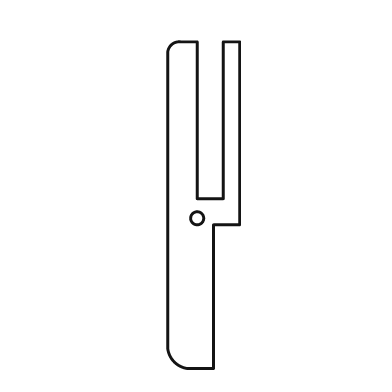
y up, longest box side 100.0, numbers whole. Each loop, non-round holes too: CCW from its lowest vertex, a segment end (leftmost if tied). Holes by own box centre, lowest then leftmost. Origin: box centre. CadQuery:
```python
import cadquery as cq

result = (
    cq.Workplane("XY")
    .moveTo(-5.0, -50.0)
    .lineTo(3.0, -50.0)
    .lineTo(3.0, -6.0)
    .lineTo(11.0, -6.0)
    .lineTo(11.0, 50.0)
    .lineTo(6.0, 50.0)
    .lineTo(6.0, 2.0)
    .lineTo(-2.0, 2.0)
    .lineTo(-2.0, 50.0)
    .lineTo(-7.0, 50.0)
    .threePointArc((-10.0, 49.0), (-11.0, 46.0))
    .lineTo(-11.0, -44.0)
    .threePointArc((-9.0, -48.0), (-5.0, -50.0))
    .close()
    .moveTo(-2.0, -4.0)
    .circle(2.0)
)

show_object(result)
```